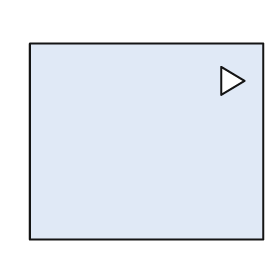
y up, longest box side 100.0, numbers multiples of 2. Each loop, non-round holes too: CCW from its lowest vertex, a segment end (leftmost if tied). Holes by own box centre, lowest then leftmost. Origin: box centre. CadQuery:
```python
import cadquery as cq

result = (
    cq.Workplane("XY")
    .moveTo(-50.0, -42.0)
    .lineTo(50.0, -42.0)
    .lineTo(50.0, 42.0)
    .lineTo(-50.0, 42.0)
    .close()
    .moveTo(32.0, 20.0)
    .lineTo(42.0, 26.0)
    .lineTo(32.0, 32.0)
    .close()
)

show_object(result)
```